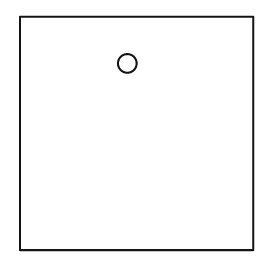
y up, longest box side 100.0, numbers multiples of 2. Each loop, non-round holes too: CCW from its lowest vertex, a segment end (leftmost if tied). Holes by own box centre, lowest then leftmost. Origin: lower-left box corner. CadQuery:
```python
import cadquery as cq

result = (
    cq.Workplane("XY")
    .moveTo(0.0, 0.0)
    .lineTo(100.0, 0.0)
    .lineTo(100.0, 100.0)
    .lineTo(0.0, 100.0)
    .close()
    .moveTo(46.0, 80.0)
    .circle(4.0)
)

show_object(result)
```